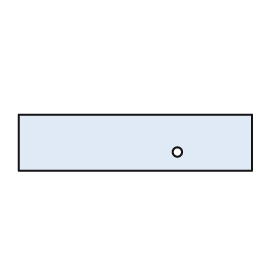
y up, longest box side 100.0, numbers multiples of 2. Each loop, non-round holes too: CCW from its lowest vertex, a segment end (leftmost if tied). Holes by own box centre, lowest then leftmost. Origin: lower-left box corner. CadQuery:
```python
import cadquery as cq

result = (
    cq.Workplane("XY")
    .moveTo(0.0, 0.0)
    .lineTo(100.0, 0.0)
    .lineTo(100.0, 24.0)
    .lineTo(0.0, 24.0)
    .close()
    .moveTo(68.0, 8.0)
    .circle(2.0)
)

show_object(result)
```